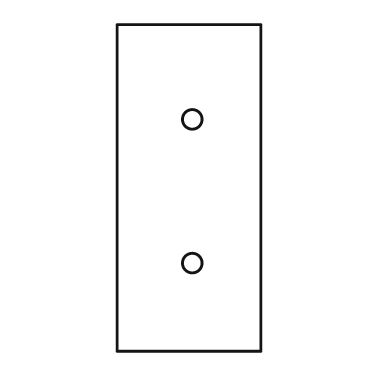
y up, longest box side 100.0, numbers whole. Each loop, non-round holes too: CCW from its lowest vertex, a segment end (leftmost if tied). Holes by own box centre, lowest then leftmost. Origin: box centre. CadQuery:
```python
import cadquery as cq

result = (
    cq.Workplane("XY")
    .moveTo(-22.0, -50.0)
    .lineTo(22.0, -50.0)
    .lineTo(22.0, 50.0)
    .lineTo(-22.0, 50.0)
    .close()
    .moveTo(1.0, -23.0)
    .circle(3.0)
    .moveTo(1.0, 21.0)
    .circle(3.0)
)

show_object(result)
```